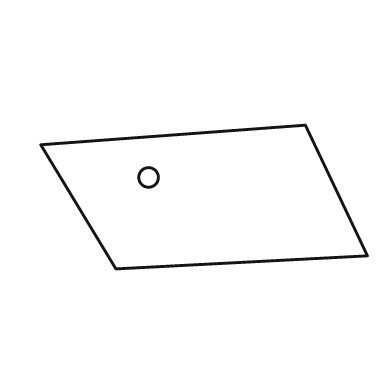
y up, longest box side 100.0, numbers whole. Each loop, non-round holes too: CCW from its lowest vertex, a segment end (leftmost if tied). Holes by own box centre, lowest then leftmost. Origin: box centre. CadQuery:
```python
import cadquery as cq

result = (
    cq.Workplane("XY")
    .moveTo(-27.0, -22.0)
    .lineTo(50.0, -18.0)
    .lineTo(31.0, 22.0)
    .lineTo(-50.0, 16.0)
    .close()
    .moveTo(-17.0, 6.0)
    .circle(3.0)
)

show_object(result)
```